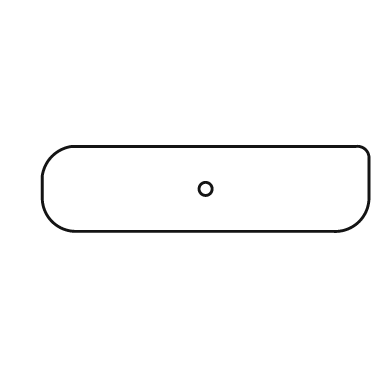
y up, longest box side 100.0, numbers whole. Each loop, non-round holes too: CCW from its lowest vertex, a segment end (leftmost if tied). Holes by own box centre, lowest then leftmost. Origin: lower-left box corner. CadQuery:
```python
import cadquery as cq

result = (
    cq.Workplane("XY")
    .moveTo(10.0, 0.0)
    .lineTo(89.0, 0.0)
    .threePointArc((97.0, 3.0), (100.0, 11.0))
    .lineTo(100.0, 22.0)
    .threePointArc((99.0, 25.0), (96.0, 26.0))
    .lineTo(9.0, 26.0)
    .threePointArc((3.0, 23.0), (0.0, 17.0))
    .lineTo(0.0, 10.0)
    .threePointArc((3.0, 3.0), (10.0, 0.0))
    .close()
    .moveTo(50.0, 13.0)
    .circle(2.0)
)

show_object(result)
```